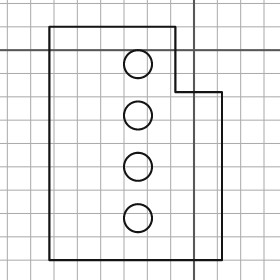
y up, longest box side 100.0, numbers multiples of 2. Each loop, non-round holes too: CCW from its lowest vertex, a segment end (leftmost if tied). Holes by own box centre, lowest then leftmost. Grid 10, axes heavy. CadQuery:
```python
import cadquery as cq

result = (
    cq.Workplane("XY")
    .moveTo(-62.0, -90.0)
    .lineTo(12.0, -90.0)
    .lineTo(12.0, -18.0)
    .lineTo(-8.0, -18.0)
    .lineTo(-8.0, 10.0)
    .lineTo(-62.0, 10.0)
    .close()
    .moveTo(-24.0, -72.0)
    .circle(6.0)
    .moveTo(-24.0, -50.0)
    .circle(6.0)
    .moveTo(-24.0, -28.0)
    .circle(6.0)
    .moveTo(-24.0, -6.0)
    .circle(6.0)
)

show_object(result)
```